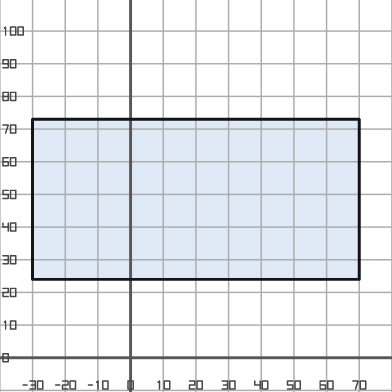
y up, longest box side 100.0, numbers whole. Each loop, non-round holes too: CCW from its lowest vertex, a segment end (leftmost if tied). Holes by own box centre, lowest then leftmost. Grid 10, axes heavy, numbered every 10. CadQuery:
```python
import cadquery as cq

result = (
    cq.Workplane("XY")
    .moveTo(-30.0, 24.0)
    .lineTo(70.0, 24.0)
    .lineTo(70.0, 73.0)
    .lineTo(-30.0, 73.0)
    .close()
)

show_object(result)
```